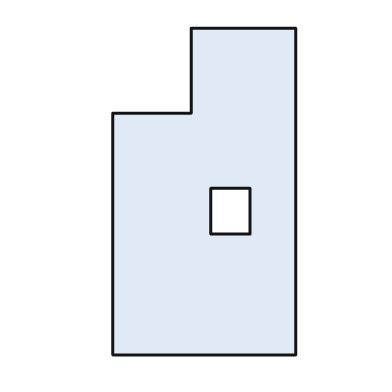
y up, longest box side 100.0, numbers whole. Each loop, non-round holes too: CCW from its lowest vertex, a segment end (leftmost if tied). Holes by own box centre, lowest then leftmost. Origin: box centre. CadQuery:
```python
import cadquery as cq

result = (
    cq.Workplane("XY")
    .moveTo(-28.0, -50.0)
    .lineTo(28.0, -50.0)
    .lineTo(28.0, 50.0)
    .lineTo(-4.0, 50.0)
    .lineTo(-4.0, 24.0)
    .lineTo(-28.0, 24.0)
    .close()
    .moveTo(2.0, -13.0)
    .lineTo(14.0, -13.0)
    .lineTo(14.0, 1.0)
    .lineTo(2.0, 1.0)
    .close()
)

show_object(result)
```